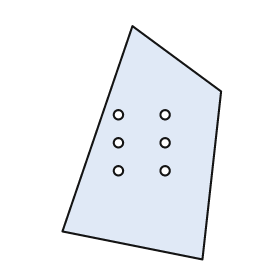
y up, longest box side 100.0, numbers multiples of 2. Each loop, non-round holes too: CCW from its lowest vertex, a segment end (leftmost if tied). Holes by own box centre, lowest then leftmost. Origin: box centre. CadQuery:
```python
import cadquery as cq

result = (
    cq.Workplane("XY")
    .moveTo(26.0, -50.0)
    .lineTo(34.0, 22.0)
    .lineTo(-4.0, 50.0)
    .lineTo(-34.0, -38.0)
    .close()
    .moveTo(-10.0, -12.0)
    .circle(2.0)
    .moveTo(10.0, -12.0)
    .circle(2.0)
    .moveTo(-10.0, 0.0)
    .circle(2.0)
    .moveTo(10.0, 0.0)
    .circle(2.0)
    .moveTo(-10.0, 12.0)
    .circle(2.0)
    .moveTo(10.0, 12.0)
    .circle(2.0)
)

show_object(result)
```